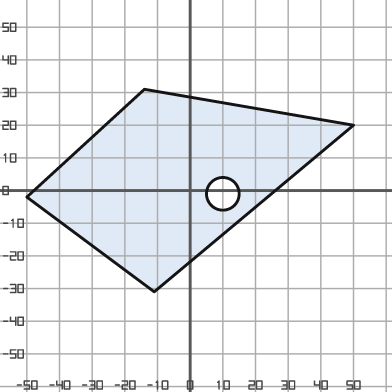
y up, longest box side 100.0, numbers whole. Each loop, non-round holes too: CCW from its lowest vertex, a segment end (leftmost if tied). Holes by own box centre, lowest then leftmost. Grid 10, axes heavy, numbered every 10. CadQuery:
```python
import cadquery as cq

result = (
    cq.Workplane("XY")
    .moveTo(-11.0, -31.0)
    .lineTo(50.0, 20.0)
    .lineTo(-14.0, 31.0)
    .lineTo(-50.0, -2.0)
    .close()
    .moveTo(10.0, -1.0)
    .circle(5.0)
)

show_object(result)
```